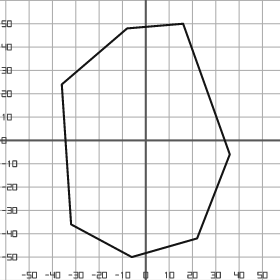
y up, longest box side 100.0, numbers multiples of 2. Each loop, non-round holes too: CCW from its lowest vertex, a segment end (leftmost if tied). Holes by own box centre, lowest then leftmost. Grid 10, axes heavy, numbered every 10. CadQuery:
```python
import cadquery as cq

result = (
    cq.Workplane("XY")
    .moveTo(-6.0, -50.0)
    .lineTo(22.0, -42.0)
    .lineTo(36.0, -6.0)
    .lineTo(16.0, 50.0)
    .lineTo(-8.0, 48.0)
    .lineTo(-36.0, 24.0)
    .lineTo(-32.0, -36.0)
    .close()
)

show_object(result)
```